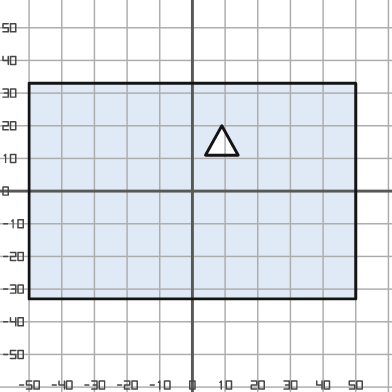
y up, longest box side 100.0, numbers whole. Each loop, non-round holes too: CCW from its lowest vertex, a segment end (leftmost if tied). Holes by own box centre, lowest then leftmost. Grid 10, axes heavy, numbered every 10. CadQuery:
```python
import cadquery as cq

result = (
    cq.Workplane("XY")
    .moveTo(-50.0, -33.0)
    .lineTo(50.0, -33.0)
    .lineTo(50.0, 33.0)
    .lineTo(-50.0, 33.0)
    .close()
    .moveTo(4.0, 11.0)
    .lineTo(14.0, 11.0)
    .lineTo(9.0, 20.0)
    .close()
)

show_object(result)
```